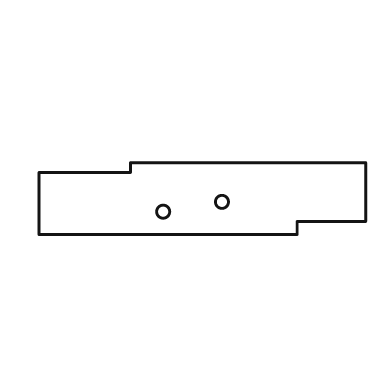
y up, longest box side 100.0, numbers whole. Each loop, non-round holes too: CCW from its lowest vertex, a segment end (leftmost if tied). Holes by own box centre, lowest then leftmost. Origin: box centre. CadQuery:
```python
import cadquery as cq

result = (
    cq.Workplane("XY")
    .moveTo(-50.0, -11.0)
    .lineTo(29.0, -11.0)
    .lineTo(29.0, -7.0)
    .lineTo(50.0, -7.0)
    .lineTo(50.0, 11.0)
    .lineTo(-22.0, 11.0)
    .lineTo(-22.0, 8.0)
    .lineTo(-50.0, 8.0)
    .close()
    .moveTo(-12.0, -4.0)
    .circle(2.0)
    .moveTo(6.0, -1.0)
    .circle(2.0)
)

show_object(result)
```